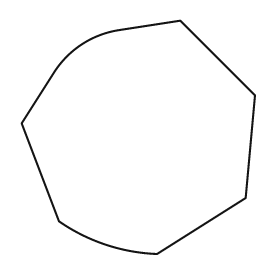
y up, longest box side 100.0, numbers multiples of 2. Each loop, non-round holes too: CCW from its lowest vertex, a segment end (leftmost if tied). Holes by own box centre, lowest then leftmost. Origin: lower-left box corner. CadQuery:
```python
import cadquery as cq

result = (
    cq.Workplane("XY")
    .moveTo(58.0, 0.0)
    .lineTo(96.0, 24.0)
    .lineTo(100.0, 68.0)
    .lineTo(68.0, 100.0)
    .lineTo(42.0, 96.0)
    .threePointArc((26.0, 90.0), (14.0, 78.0))
    .lineTo(0.0, 56.0)
    .lineTo(16.0, 14.0)
    .threePointArc((36.0, 4.0), (58.0, 0.0))
    .close()
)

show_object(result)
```